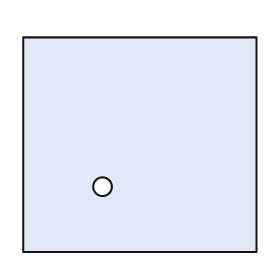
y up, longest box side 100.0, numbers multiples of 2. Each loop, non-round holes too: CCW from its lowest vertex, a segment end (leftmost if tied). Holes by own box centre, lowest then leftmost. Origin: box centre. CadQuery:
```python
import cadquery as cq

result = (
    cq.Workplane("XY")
    .moveTo(-50.0, -46.0)
    .lineTo(50.0, -46.0)
    .lineTo(50.0, 46.0)
    .lineTo(-50.0, 46.0)
    .close()
    .moveTo(-16.0, -18.0)
    .circle(4.0)
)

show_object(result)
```